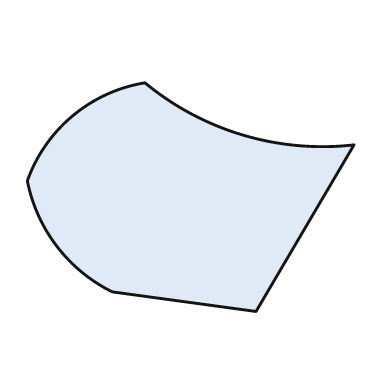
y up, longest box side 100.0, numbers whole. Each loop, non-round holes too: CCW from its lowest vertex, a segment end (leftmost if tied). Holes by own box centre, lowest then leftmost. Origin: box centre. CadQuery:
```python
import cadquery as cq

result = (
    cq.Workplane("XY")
    .moveTo(20.0, -35.0)
    .lineTo(50.0, 16.0)
    .threePointArc((16.0, 19.0), (-14.0, 35.0))
    .threePointArc((-36.0, 25.0), (-50.0, 5.0))
    .threePointArc((-41.0, -15.0), (-24.0, -29.0))
    .close()
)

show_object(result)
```